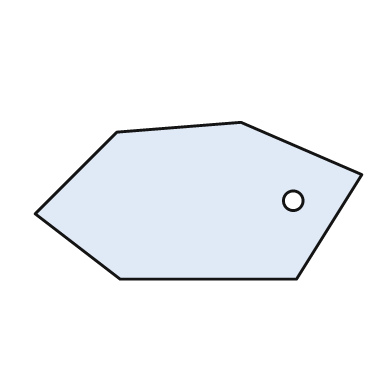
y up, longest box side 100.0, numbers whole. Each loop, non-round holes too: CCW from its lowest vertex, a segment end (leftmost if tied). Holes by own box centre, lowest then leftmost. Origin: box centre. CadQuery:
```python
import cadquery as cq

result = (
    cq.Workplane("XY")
    .moveTo(-24.0, -24.0)
    .lineTo(30.0, -24.0)
    .lineTo(50.0, 8.0)
    .lineTo(13.0, 24.0)
    .lineTo(-25.0, 21.0)
    .lineTo(-50.0, -4.0)
    .close()
    .moveTo(29.0, 0.0)
    .circle(3.0)
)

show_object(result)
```